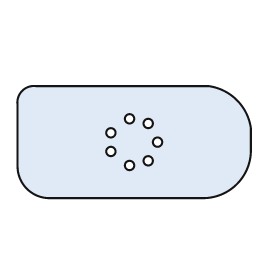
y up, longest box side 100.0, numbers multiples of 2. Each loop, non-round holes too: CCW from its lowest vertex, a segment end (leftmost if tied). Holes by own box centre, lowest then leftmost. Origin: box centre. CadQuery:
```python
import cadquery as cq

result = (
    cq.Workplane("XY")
    .moveTo(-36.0, -24.0)
    .lineTo(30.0, -24.0)
    .threePointArc((44.0, -18.0), (50.0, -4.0))
    .lineTo(50.0, 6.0)
    .threePointArc((44.0, 18.0), (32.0, 24.0))
    .lineTo(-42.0, 24.0)
    .threePointArc((-48.0, 22.0), (-50.0, 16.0))
    .lineTo(-50.0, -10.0)
    .threePointArc((-46.0, -20.0), (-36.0, -24.0))
    .close()
    .moveTo(-2.0, -10.0)
    .circle(2.0)
    .moveTo(6.0, -8.0)
    .circle(2.0)
    .moveTo(-10.0, -4.0)
    .circle(2.0)
    .moveTo(10.0, 0.0)
    .circle(2.0)
    .moveTo(-10.0, 4.0)
    .circle(2.0)
    .moveTo(6.0, 8.0)
    .circle(2.0)
    .moveTo(-2.0, 10.0)
    .circle(2.0)
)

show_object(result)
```